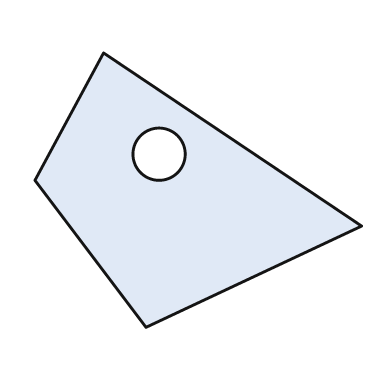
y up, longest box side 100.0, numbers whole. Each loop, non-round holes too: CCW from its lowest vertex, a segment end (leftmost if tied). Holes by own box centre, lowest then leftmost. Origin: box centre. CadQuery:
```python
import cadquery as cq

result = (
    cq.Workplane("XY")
    .moveTo(-16.0, -42.0)
    .lineTo(50.0, -11.0)
    .lineTo(-29.0, 42.0)
    .lineTo(-50.0, 3.0)
    .close()
    .moveTo(-12.0, 11.0)
    .circle(8.0)
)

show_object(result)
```